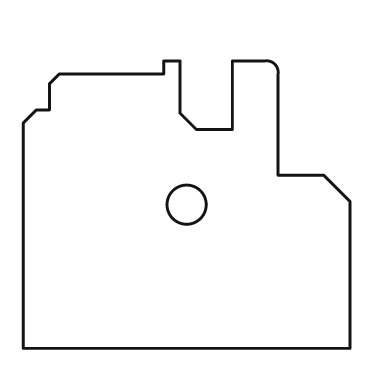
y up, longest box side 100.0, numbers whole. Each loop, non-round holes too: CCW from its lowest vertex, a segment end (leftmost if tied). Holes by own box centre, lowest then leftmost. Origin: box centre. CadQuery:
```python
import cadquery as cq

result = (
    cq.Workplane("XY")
    .moveTo(-50.0, -44.0)
    .lineTo(50.0, -44.0)
    .lineTo(50.0, 1.0)
    .lineTo(42.0, 9.0)
    .lineTo(28.0, 9.0)
    .lineTo(28.0, 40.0)
    .threePointArc((27.0, 43.0), (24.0, 44.0))
    .lineTo(14.0, 44.0)
    .lineTo(14.0, 23.0)
    .lineTo(3.0, 23.0)
    .lineTo(-2.0, 28.0)
    .lineTo(-2.0, 44.0)
    .lineTo(-7.0, 44.0)
    .lineTo(-7.0, 40.0)
    .lineTo(-39.0, 40.0)
    .lineTo(-42.0, 37.0)
    .lineTo(-42.0, 29.0)
    .lineTo(-46.0, 29.0)
    .lineTo(-50.0, 25.0)
    .close()
    .moveTo(0.0, 0.0)
    .circle(6.0)
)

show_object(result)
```